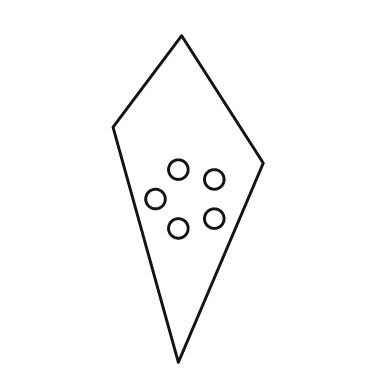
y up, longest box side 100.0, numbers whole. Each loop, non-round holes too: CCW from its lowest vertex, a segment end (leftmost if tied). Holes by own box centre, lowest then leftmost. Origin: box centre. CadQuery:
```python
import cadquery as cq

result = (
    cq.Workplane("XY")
    .moveTo(-3.0, -50.0)
    .lineTo(23.0, 11.0)
    .lineTo(-2.0, 50.0)
    .lineTo(-23.0, 22.0)
    .close()
    .moveTo(-3.0, -9.0)
    .circle(3.0)
    .moveTo(8.0, -6.0)
    .circle(3.0)
    .moveTo(-10.0, 0.0)
    .circle(3.0)
    .moveTo(8.0, 6.0)
    .circle(3.0)
    .moveTo(-3.0, 9.0)
    .circle(3.0)
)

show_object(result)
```